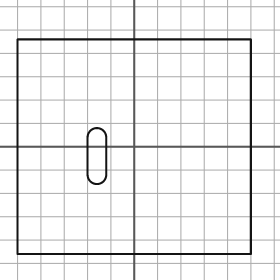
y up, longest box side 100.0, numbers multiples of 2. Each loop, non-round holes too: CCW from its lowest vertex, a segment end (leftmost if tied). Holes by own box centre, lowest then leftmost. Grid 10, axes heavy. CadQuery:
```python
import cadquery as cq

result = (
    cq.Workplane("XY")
    .moveTo(-50.0, -46.0)
    .lineTo(50.0, -46.0)
    .lineTo(50.0, 46.0)
    .lineTo(-50.0, 46.0)
    .close()
    .moveTo(-20.0, -12.0)
    .threePointArc((-16.0, -16.0), (-12.0, -12.0))
    .lineTo(-12.0, 4.0)
    .threePointArc((-16.0, 8.0), (-20.0, 4.0))
    .close()
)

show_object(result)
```